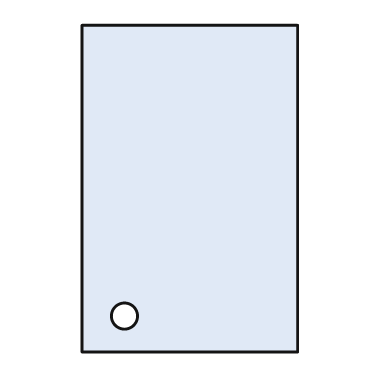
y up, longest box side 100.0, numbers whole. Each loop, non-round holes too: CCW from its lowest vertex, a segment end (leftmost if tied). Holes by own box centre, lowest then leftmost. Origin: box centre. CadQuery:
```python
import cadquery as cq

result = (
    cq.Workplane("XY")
    .moveTo(-33.0, -50.0)
    .lineTo(33.0, -50.0)
    .lineTo(33.0, 50.0)
    .lineTo(-33.0, 50.0)
    .close()
    .moveTo(-20.0, -39.0)
    .circle(4.0)
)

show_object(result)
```